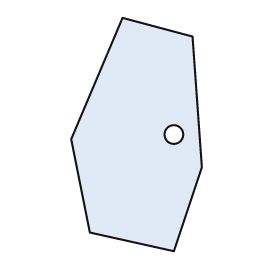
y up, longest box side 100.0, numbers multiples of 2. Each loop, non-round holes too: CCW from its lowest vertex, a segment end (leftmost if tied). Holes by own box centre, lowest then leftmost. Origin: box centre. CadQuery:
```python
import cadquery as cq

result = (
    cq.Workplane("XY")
    .moveTo(16.0, -50.0)
    .lineTo(28.0, -14.0)
    .lineTo(24.0, 42.0)
    .lineTo(-6.0, 50.0)
    .lineTo(-28.0, -2.0)
    .lineTo(-20.0, -42.0)
    .close()
    .moveTo(16.0, 0.0)
    .circle(4.0)
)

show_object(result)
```